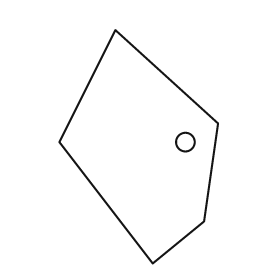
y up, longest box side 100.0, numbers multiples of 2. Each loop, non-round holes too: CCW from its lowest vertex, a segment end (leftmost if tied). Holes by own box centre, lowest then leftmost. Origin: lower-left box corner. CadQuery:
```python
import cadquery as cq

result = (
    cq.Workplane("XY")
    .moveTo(40.0, 0.0)
    .lineTo(62.0, 18.0)
    .lineTo(68.0, 60.0)
    .lineTo(24.0, 100.0)
    .lineTo(0.0, 52.0)
    .close()
    .moveTo(54.0, 52.0)
    .circle(4.0)
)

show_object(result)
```